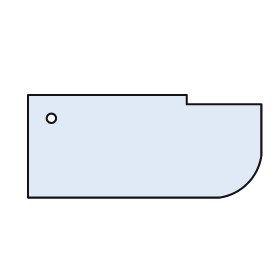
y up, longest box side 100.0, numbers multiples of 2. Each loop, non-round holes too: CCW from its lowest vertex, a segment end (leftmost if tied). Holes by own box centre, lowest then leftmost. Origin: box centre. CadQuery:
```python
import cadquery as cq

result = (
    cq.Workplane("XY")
    .moveTo(-50.0, -22.0)
    .lineTo(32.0, -22.0)
    .threePointArc((44.0, -16.0), (50.0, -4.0))
    .lineTo(50.0, 18.0)
    .lineTo(18.0, 18.0)
    .lineTo(18.0, 22.0)
    .lineTo(-50.0, 22.0)
    .close()
    .moveTo(-40.0, 12.0)
    .circle(2.0)
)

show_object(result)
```